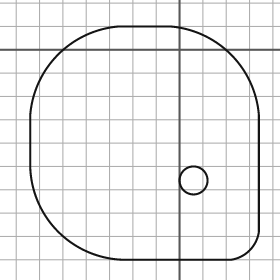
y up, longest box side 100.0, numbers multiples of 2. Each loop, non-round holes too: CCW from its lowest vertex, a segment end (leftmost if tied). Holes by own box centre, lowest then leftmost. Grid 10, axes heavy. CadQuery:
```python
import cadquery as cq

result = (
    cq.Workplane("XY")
    .moveTo(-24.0, -90.0)
    .lineTo(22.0, -90.0)
    .threePointArc((30.0, -86.0), (34.0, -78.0))
    .lineTo(34.0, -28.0)
    .threePointArc((22.0, -2.0), (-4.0, 10.0))
    .lineTo(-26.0, 10.0)
    .threePointArc((-52.0, -2.0), (-64.0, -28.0))
    .lineTo(-64.0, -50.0)
    .threePointArc((-52.0, -78.0), (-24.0, -90.0))
    .close()
    .moveTo(6.0, -56.0)
    .circle(6.0)
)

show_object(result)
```